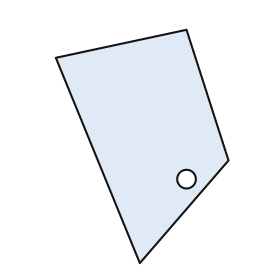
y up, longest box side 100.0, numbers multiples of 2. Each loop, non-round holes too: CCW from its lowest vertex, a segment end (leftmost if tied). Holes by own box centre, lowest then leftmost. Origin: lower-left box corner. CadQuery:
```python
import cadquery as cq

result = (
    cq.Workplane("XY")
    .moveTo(36.0, 0.0)
    .lineTo(74.0, 44.0)
    .lineTo(56.0, 100.0)
    .lineTo(0.0, 88.0)
    .close()
    .moveTo(56.0, 36.0)
    .circle(4.0)
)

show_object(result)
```